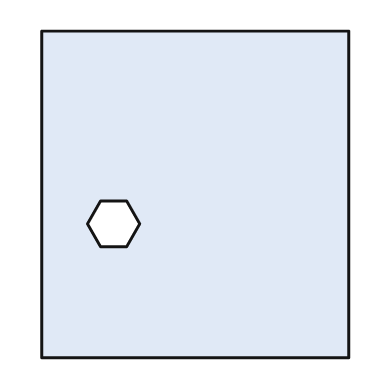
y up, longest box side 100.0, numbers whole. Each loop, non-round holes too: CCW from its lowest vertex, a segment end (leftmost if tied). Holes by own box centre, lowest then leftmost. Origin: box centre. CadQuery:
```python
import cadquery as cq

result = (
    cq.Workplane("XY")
    .moveTo(-47.0, -50.0)
    .lineTo(47.0, -50.0)
    .lineTo(47.0, 50.0)
    .lineTo(-47.0, 50.0)
    .close()
    .moveTo(-29.0, -16.0)
    .lineTo(-21.0, -16.0)
    .lineTo(-17.0, -9.0)
    .lineTo(-21.0, -2.0)
    .lineTo(-29.0, -2.0)
    .lineTo(-33.0, -9.0)
    .close()
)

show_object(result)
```